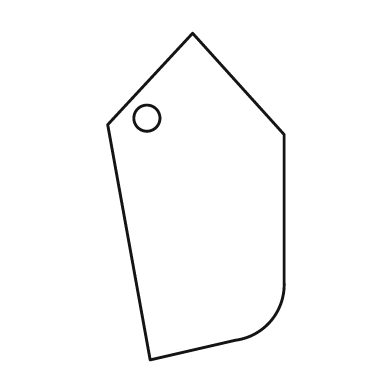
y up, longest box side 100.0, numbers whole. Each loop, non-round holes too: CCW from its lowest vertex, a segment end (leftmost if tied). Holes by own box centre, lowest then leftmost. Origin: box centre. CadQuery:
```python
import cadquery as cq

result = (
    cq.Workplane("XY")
    .moveTo(-14.0, -50.0)
    .lineTo(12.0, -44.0)
    .threePointArc((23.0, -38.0), (27.0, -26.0))
    .lineTo(27.0, 19.0)
    .lineTo(-1.0, 50.0)
    .lineTo(-27.0, 22.0)
    .close()
    .moveTo(-15.0, 24.0)
    .circle(4.0)
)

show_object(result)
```